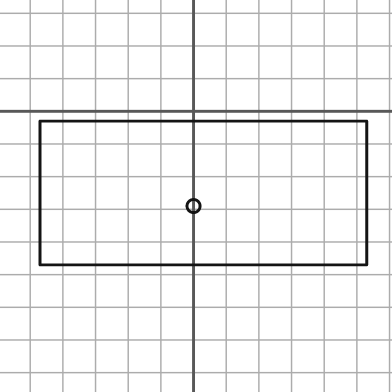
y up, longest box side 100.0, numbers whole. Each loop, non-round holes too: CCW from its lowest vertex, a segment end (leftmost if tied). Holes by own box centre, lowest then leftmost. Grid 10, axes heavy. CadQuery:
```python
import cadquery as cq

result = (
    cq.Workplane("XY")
    .moveTo(-47.0, -47.0)
    .lineTo(53.0, -47.0)
    .lineTo(53.0, -3.0)
    .lineTo(-47.0, -3.0)
    .close()
    .moveTo(0.0, -29.0)
    .circle(2.0)
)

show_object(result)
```